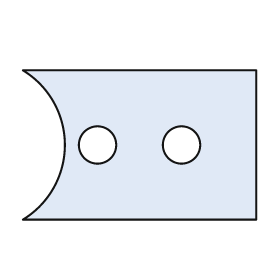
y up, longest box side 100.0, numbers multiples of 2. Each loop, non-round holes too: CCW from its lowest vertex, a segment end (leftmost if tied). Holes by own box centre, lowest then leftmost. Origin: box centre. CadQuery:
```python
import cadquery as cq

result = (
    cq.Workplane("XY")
    .moveTo(-50.0, -32.0)
    .lineTo(50.0, -32.0)
    .lineTo(50.0, 32.0)
    .lineTo(-50.0, 32.0)
    .threePointArc((-32.0, 0.0), (-50.0, -32.0))
    .close()
    .moveTo(-18.0, 0.0)
    .circle(8.0)
    .moveTo(18.0, 0.0)
    .circle(8.0)
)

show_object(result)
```